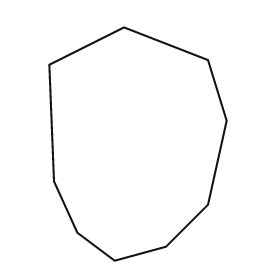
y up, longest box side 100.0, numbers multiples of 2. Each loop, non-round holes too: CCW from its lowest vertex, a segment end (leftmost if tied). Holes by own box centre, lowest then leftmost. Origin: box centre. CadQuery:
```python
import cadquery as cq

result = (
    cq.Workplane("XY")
    .moveTo(-10.0, -50.0)
    .lineTo(12.0, -44.0)
    .lineTo(30.0, -26.0)
    .lineTo(38.0, 10.0)
    .lineTo(30.0, 36.0)
    .lineTo(-6.0, 50.0)
    .lineTo(-38.0, 34.0)
    .lineTo(-36.0, -16.0)
    .lineTo(-26.0, -38.0)
    .close()
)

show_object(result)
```